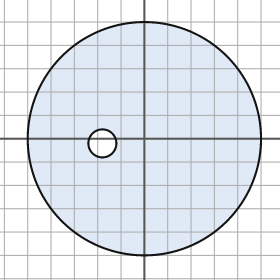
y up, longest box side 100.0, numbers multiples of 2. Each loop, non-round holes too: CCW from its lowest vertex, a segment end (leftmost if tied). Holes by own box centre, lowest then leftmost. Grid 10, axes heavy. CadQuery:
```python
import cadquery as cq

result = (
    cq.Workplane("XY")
    .moveTo(0.0, 0.0)
    .circle(50.0)
    .moveTo(-18.0, -2.0)
    .circle(6.0)
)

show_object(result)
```